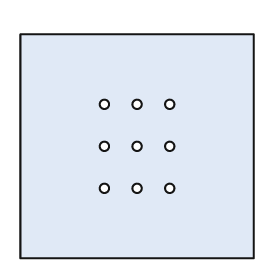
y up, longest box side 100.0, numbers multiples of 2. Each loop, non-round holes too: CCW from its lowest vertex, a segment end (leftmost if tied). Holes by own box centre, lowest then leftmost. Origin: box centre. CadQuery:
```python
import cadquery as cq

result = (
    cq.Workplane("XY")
    .moveTo(-50.0, -48.0)
    .lineTo(50.0, -48.0)
    .lineTo(50.0, 48.0)
    .lineTo(-50.0, 48.0)
    .close()
    .moveTo(-14.0, -18.0)
    .circle(2.0)
    .moveTo(0.0, -18.0)
    .circle(2.0)
    .moveTo(14.0, -18.0)
    .circle(2.0)
    .moveTo(-14.0, 0.0)
    .circle(2.0)
    .moveTo(0.0, 0.0)
    .circle(2.0)
    .moveTo(14.0, 0.0)
    .circle(2.0)
    .moveTo(-14.0, 18.0)
    .circle(2.0)
    .moveTo(0.0, 18.0)
    .circle(2.0)
    .moveTo(14.0, 18.0)
    .circle(2.0)
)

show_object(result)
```